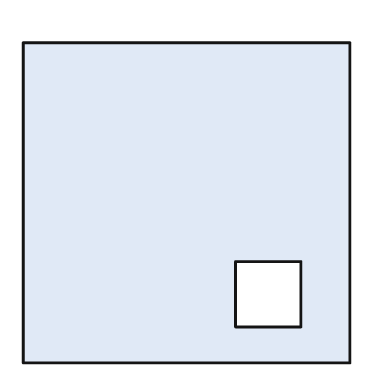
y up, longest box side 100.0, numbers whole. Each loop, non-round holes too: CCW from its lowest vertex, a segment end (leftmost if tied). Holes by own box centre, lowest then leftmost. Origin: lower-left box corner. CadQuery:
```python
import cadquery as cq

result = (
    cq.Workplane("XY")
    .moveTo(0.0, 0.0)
    .lineTo(100.0, 0.0)
    .lineTo(100.0, 98.0)
    .lineTo(0.0, 98.0)
    .close()
    .moveTo(65.0, 11.0)
    .lineTo(85.0, 11.0)
    .lineTo(85.0, 31.0)
    .lineTo(65.0, 31.0)
    .close()
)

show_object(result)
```